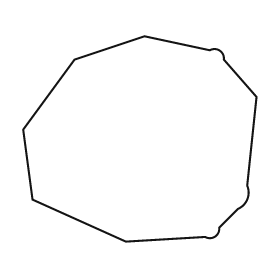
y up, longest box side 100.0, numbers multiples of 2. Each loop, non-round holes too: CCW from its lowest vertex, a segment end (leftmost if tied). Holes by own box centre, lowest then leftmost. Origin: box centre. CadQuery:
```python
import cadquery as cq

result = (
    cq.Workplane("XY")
    .moveTo(-6.0, -44.0)
    .lineTo(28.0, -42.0)
    .threePointArc((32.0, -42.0), (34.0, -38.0))
    .lineTo(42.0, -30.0)
    .threePointArc((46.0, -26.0), (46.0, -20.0))
    .lineTo(50.0, 18.0)
    .lineTo(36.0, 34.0)
    .threePointArc((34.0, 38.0), (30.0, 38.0))
    .lineTo(2.0, 44.0)
    .lineTo(-28.0, 34.0)
    .lineTo(-50.0, 4.0)
    .lineTo(-46.0, -26.0)
    .close()
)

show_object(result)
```